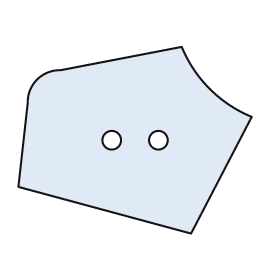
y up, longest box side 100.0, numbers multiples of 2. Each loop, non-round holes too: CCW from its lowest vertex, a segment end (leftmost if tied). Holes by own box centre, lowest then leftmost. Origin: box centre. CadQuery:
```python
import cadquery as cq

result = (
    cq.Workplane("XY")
    .moveTo(24.0, -40.0)
    .lineTo(50.0, 10.0)
    .threePointArc((32.0, 22.0), (20.0, 40.0))
    .lineTo(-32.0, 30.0)
    .threePointArc((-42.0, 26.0), (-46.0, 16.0))
    .lineTo(-50.0, -20.0)
    .close()
    .moveTo(-10.0, 0.0)
    .circle(4.0)
    .moveTo(10.0, 0.0)
    .circle(4.0)
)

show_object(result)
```